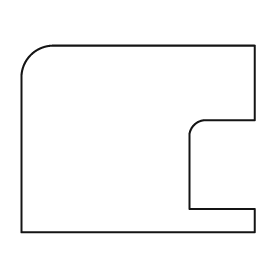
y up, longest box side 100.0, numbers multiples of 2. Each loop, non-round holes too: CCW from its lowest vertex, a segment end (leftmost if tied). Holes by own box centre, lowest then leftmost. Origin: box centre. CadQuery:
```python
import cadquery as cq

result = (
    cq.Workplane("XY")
    .moveTo(-50.0, -40.0)
    .lineTo(50.0, -40.0)
    .lineTo(50.0, -30.0)
    .lineTo(22.0, -30.0)
    .lineTo(22.0, 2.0)
    .threePointArc((24.0, 6.0), (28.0, 8.0))
    .lineTo(50.0, 8.0)
    .lineTo(50.0, 40.0)
    .lineTo(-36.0, 40.0)
    .threePointArc((-46.0, 36.0), (-50.0, 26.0))
    .close()
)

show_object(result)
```